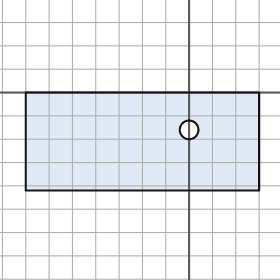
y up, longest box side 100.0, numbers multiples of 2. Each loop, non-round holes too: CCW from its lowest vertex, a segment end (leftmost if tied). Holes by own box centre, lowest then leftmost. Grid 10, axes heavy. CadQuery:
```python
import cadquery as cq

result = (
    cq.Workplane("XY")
    .moveTo(-70.0, -42.0)
    .lineTo(30.0, -42.0)
    .lineTo(30.0, 0.0)
    .lineTo(-70.0, 0.0)
    .close()
    .moveTo(0.0, -16.0)
    .circle(4.0)
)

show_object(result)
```